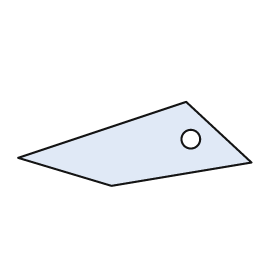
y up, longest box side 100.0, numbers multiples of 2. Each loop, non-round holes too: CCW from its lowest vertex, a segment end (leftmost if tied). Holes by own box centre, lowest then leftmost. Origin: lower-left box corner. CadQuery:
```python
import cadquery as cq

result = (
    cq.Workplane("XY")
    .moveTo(40.0, 0.0)
    .lineTo(100.0, 10.0)
    .lineTo(72.0, 36.0)
    .lineTo(0.0, 12.0)
    .close()
    .moveTo(74.0, 20.0)
    .circle(4.0)
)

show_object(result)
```